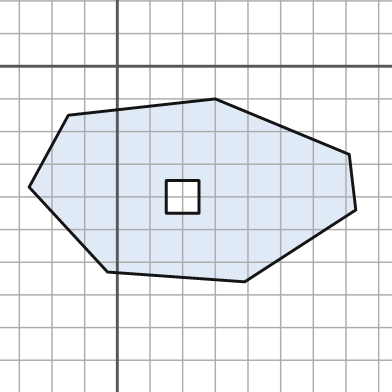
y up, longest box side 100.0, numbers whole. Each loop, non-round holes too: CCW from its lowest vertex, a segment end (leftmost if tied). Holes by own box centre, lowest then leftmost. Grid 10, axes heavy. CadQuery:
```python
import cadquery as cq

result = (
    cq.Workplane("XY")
    .moveTo(39.0, -66.0)
    .lineTo(73.0, -44.0)
    .lineTo(71.0, -27.0)
    .lineTo(30.0, -10.0)
    .lineTo(-15.0, -15.0)
    .lineTo(-27.0, -37.0)
    .lineTo(-3.0, -63.0)
    .close()
    .moveTo(15.0, -45.0)
    .lineTo(25.0, -45.0)
    .lineTo(25.0, -35.0)
    .lineTo(15.0, -35.0)
    .close()
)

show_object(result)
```